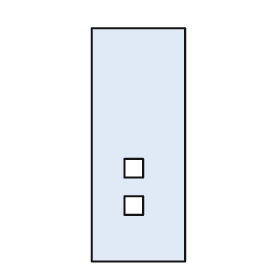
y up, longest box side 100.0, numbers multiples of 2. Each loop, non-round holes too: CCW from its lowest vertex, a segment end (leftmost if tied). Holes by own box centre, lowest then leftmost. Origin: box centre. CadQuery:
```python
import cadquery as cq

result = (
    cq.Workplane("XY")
    .moveTo(-20.0, -50.0)
    .lineTo(20.0, -50.0)
    .lineTo(20.0, 50.0)
    .lineTo(-20.0, 50.0)
    .close()
    .moveTo(-6.0, -30.0)
    .lineTo(2.0, -30.0)
    .lineTo(2.0, -22.0)
    .lineTo(-6.0, -22.0)
    .close()
    .moveTo(-6.0, -14.0)
    .lineTo(2.0, -14.0)
    .lineTo(2.0, -6.0)
    .lineTo(-6.0, -6.0)
    .close()
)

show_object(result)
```